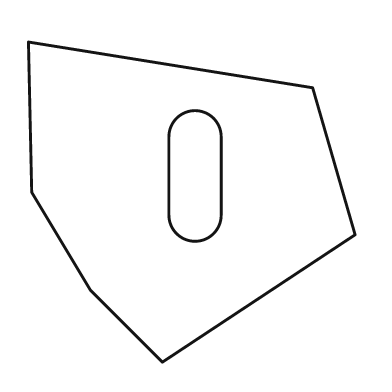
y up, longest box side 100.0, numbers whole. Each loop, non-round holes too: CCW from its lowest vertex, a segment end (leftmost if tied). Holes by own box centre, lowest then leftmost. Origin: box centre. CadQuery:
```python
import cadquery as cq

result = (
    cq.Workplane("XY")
    .moveTo(-9.0, -49.0)
    .lineTo(50.0, -10.0)
    .lineTo(37.0, 35.0)
    .lineTo(-50.0, 49.0)
    .lineTo(-49.0, 3.0)
    .lineTo(-31.0, -27.0)
    .close()
    .moveTo(-7.0, -4.0)
    .threePointArc((1.0, -12.0), (9.0, -4.0))
    .lineTo(9.0, 20.0)
    .threePointArc((1.0, 28.0), (-7.0, 20.0))
    .close()
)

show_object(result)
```